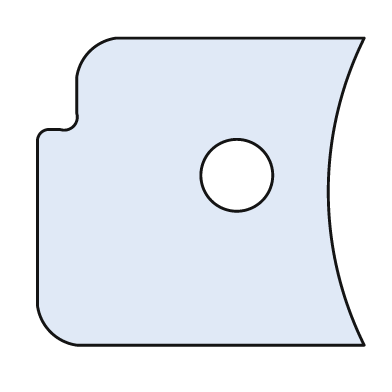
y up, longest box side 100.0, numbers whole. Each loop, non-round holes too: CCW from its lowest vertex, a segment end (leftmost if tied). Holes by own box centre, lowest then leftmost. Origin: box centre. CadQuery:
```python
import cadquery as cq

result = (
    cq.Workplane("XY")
    .moveTo(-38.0, -47.0)
    .lineTo(50.0, -47.0)
    .threePointArc((39.0, 0.0), (50.0, 47.0))
    .lineTo(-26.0, 47.0)
    .threePointArc((-34.0, 43.0), (-38.0, 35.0))
    .lineTo(-38.0, 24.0)
    .threePointArc((-39.0, 20.0), (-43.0, 19.0))
    .lineTo(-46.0, 19.0)
    .threePointArc((-49.0, 18.0), (-50.0, 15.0))
    .lineTo(-50.0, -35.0)
    .threePointArc((-46.0, -43.0), (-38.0, -47.0))
    .close()
    .moveTo(11.0, 5.0)
    .circle(11.0)
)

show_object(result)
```